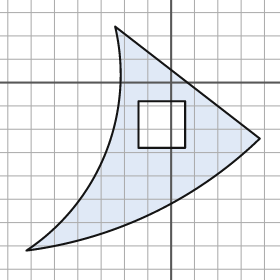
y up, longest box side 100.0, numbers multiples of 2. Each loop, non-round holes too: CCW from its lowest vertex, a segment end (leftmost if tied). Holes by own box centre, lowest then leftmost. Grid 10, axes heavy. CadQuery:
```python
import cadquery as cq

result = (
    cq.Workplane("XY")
    .moveTo(-62.0, -72.0)
    .threePointArc((-8.0, -56.0), (38.0, -24.0))
    .lineTo(-24.0, 24.0)
    .threePointArc((-28.0, -30.0), (-62.0, -72.0))
    .close()
    .moveTo(-14.0, -28.0)
    .lineTo(6.0, -28.0)
    .lineTo(6.0, -8.0)
    .lineTo(-14.0, -8.0)
    .close()
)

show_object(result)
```